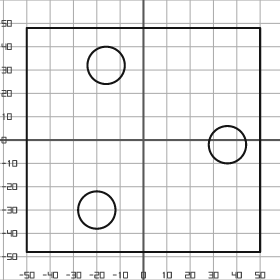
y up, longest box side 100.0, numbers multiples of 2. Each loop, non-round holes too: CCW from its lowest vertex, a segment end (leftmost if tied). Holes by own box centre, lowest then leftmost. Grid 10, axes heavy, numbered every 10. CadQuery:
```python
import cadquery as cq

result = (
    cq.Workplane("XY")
    .moveTo(-50.0, -48.0)
    .lineTo(50.0, -48.0)
    .lineTo(50.0, 48.0)
    .lineTo(-50.0, 48.0)
    .close()
    .moveTo(-20.0, -30.0)
    .circle(8.0)
    .moveTo(36.0, -2.0)
    .circle(8.0)
    .moveTo(-16.0, 32.0)
    .circle(8.0)
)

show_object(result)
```